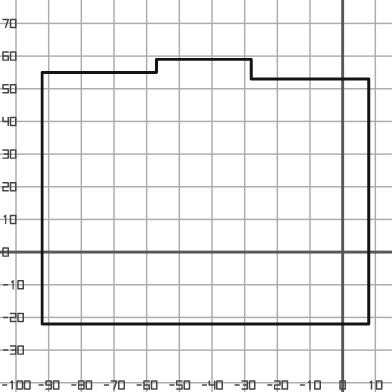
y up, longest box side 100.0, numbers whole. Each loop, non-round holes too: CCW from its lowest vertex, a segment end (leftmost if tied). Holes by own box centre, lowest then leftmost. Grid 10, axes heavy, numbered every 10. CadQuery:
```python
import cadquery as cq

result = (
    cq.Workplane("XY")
    .moveTo(-92.0, -22.0)
    .lineTo(8.0, -22.0)
    .lineTo(8.0, 53.0)
    .lineTo(-28.0, 53.0)
    .lineTo(-28.0, 59.0)
    .lineTo(-57.0, 59.0)
    .lineTo(-57.0, 55.0)
    .lineTo(-92.0, 55.0)
    .close()
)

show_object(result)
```